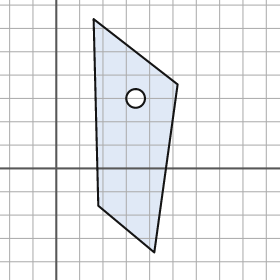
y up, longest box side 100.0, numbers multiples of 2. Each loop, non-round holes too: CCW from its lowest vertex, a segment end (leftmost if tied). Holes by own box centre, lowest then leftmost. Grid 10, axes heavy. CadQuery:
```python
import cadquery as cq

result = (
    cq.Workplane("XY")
    .moveTo(42.0, -36.0)
    .lineTo(52.0, 36.0)
    .lineTo(16.0, 64.0)
    .lineTo(18.0, -16.0)
    .close()
    .moveTo(34.0, 30.0)
    .circle(4.0)
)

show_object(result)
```